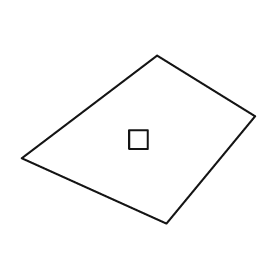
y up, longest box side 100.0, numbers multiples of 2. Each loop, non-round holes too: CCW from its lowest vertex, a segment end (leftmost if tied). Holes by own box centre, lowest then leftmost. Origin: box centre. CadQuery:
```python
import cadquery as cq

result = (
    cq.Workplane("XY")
    .moveTo(12.0, -36.0)
    .lineTo(50.0, 10.0)
    .lineTo(8.0, 36.0)
    .lineTo(-50.0, -8.0)
    .close()
    .moveTo(-4.0, -4.0)
    .lineTo(4.0, -4.0)
    .lineTo(4.0, 4.0)
    .lineTo(-4.0, 4.0)
    .close()
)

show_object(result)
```